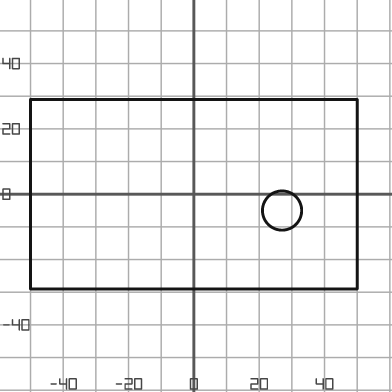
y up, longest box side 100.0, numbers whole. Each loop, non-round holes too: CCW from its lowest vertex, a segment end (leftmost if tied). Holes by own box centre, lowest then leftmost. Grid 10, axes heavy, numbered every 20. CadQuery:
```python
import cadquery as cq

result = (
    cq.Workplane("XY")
    .moveTo(-50.0, -29.0)
    .lineTo(50.0, -29.0)
    .lineTo(50.0, 29.0)
    .lineTo(-50.0, 29.0)
    .close()
    .moveTo(27.0, -5.0)
    .circle(6.0)
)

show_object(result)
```